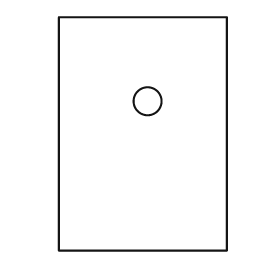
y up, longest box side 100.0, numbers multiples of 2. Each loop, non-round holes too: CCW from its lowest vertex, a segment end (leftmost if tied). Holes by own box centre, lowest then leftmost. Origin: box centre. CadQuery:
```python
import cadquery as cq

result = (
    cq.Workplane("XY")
    .moveTo(-36.0, -50.0)
    .lineTo(36.0, -50.0)
    .lineTo(36.0, 50.0)
    .lineTo(-36.0, 50.0)
    .close()
    .moveTo(2.0, 14.0)
    .circle(6.0)
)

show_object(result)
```